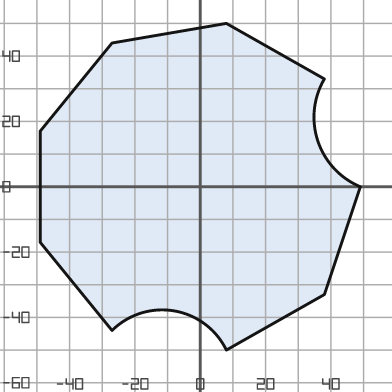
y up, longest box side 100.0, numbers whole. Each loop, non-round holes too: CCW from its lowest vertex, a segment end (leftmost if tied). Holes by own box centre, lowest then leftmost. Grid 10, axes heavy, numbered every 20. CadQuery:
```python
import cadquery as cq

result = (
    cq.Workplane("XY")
    .moveTo(8.0, -50.0)
    .lineTo(38.0, -33.0)
    .lineTo(49.0, 0.0)
    .threePointArc((36.0, 14.0), (38.0, 33.0))
    .lineTo(8.0, 50.0)
    .lineTo(-27.0, 44.0)
    .lineTo(-49.0, 17.0)
    .lineTo(-49.0, -17.0)
    .lineTo(-27.0, -44.0)
    .threePointArc((-8.0, -38.0), (8.0, -50.0))
    .close()
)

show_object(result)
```